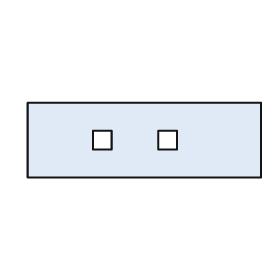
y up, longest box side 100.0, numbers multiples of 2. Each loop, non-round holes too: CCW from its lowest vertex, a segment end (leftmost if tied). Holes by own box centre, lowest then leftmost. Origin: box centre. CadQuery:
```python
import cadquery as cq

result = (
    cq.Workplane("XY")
    .moveTo(-50.0, -16.0)
    .lineTo(50.0, -16.0)
    .lineTo(50.0, 16.0)
    .lineTo(-50.0, 16.0)
    .close()
    .moveTo(-22.0, -4.0)
    .lineTo(-14.0, -4.0)
    .lineTo(-14.0, 4.0)
    .lineTo(-22.0, 4.0)
    .close()
    .moveTo(6.0, -4.0)
    .lineTo(14.0, -4.0)
    .lineTo(14.0, 4.0)
    .lineTo(6.0, 4.0)
    .close()
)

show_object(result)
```